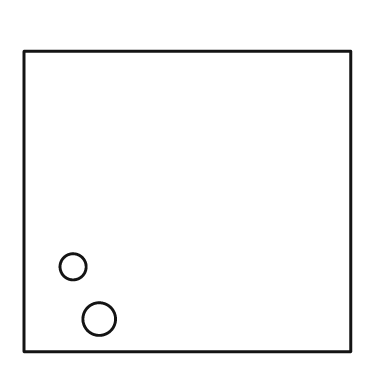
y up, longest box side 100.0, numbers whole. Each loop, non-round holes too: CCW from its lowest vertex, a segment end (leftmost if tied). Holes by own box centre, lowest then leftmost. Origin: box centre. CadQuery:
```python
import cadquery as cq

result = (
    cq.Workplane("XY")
    .moveTo(-50.0, -46.0)
    .lineTo(50.0, -46.0)
    .lineTo(50.0, 46.0)
    .lineTo(-50.0, 46.0)
    .close()
    .moveTo(-27.0, -36.0)
    .circle(5.0)
    .moveTo(-35.0, -20.0)
    .circle(4.0)
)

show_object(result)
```